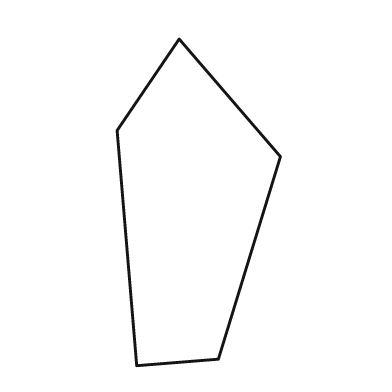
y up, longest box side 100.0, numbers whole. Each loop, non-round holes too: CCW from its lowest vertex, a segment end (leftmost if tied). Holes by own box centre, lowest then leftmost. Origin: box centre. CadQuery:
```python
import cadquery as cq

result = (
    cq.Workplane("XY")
    .moveTo(-19.0, -50.0)
    .lineTo(6.0, -48.0)
    .lineTo(25.0, 14.0)
    .lineTo(-6.0, 50.0)
    .lineTo(-25.0, 22.0)
    .close()
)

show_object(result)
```